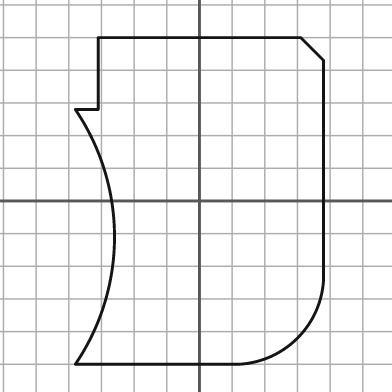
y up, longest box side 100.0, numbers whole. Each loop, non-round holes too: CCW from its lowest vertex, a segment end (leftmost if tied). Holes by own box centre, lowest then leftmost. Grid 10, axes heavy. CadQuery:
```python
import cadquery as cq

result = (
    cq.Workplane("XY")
    .moveTo(-38.0, -50.0)
    .lineTo(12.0, -50.0)
    .threePointArc((30.0, -42.0), (38.0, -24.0))
    .lineTo(38.0, 43.0)
    .lineTo(31.0, 50.0)
    .lineTo(-31.0, 50.0)
    .lineTo(-31.0, 28.0)
    .lineTo(-38.0, 28.0)
    .threePointArc((-26.0, -11.0), (-38.0, -50.0))
    .close()
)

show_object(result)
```